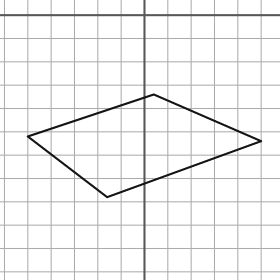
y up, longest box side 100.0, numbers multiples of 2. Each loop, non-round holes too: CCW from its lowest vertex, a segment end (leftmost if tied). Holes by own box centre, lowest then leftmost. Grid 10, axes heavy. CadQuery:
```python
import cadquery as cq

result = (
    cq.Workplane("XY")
    .moveTo(-16.0, -78.0)
    .lineTo(50.0, -54.0)
    .lineTo(4.0, -34.0)
    .lineTo(-50.0, -52.0)
    .close()
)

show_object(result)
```